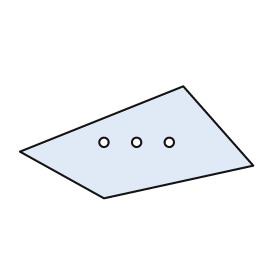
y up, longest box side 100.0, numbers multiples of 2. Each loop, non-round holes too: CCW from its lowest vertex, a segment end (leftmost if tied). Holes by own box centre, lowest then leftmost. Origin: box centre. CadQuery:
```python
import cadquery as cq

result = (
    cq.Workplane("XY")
    .moveTo(-14.0, -24.0)
    .lineTo(50.0, -10.0)
    .lineTo(20.0, 24.0)
    .lineTo(-50.0, -4.0)
    .close()
    .moveTo(-14.0, 0.0)
    .circle(2.0)
    .moveTo(0.0, 0.0)
    .circle(2.0)
    .moveTo(14.0, 0.0)
    .circle(2.0)
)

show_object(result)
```